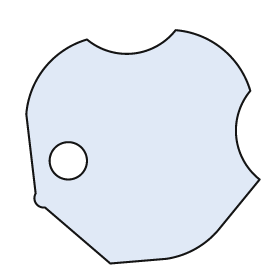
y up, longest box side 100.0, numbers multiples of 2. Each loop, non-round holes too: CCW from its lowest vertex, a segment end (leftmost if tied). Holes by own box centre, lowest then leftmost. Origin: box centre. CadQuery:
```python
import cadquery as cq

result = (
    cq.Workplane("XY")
    .moveTo(-14.0, -50.0)
    .lineTo(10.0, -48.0)
    .threePointArc((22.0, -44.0), (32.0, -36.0))
    .lineTo(50.0, -14.0)
    .threePointArc((40.0, 4.0), (46.0, 24.0))
    .threePointArc((34.0, 42.0), (14.0, 50.0))
    .threePointArc((-4.0, 40.0), (-24.0, 46.0))
    .threePointArc((-42.0, 34.0), (-50.0, 14.0))
    .lineTo(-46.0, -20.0)
    .threePointArc((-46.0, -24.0), (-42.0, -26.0))
    .close()
    .moveTo(-32.0, -6.0)
    .circle(8.0)
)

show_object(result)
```